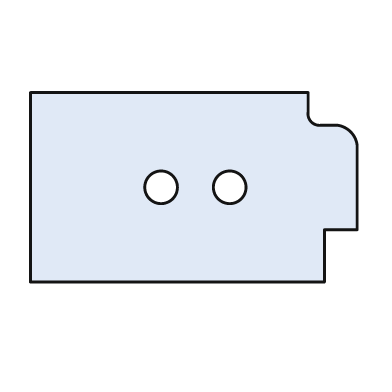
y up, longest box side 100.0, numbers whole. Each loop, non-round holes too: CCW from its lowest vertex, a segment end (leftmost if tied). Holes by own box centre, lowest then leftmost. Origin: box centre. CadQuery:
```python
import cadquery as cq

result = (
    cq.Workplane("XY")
    .moveTo(-50.0, -29.0)
    .lineTo(40.0, -29.0)
    .lineTo(40.0, -13.0)
    .lineTo(50.0, -13.0)
    .lineTo(50.0, 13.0)
    .threePointArc((48.0, 17.0), (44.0, 19.0))
    .lineTo(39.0, 19.0)
    .threePointArc((36.0, 20.0), (35.0, 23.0))
    .lineTo(35.0, 29.0)
    .lineTo(-50.0, 29.0)
    .close()
    .moveTo(-10.0, 0.0)
    .circle(5.0)
    .moveTo(11.0, 0.0)
    .circle(5.0)
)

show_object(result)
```